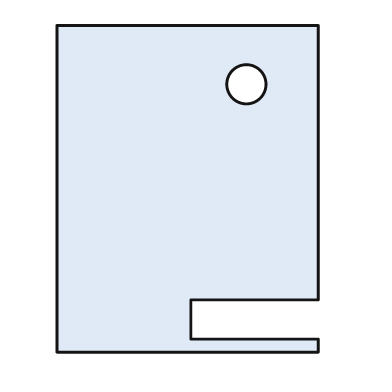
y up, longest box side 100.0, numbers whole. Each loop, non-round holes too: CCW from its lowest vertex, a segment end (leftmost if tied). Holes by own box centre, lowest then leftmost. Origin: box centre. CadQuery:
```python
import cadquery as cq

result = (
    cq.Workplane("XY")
    .moveTo(-40.0, -50.0)
    .lineTo(40.0, -50.0)
    .lineTo(40.0, -46.0)
    .lineTo(1.0, -46.0)
    .lineTo(1.0, -34.0)
    .lineTo(40.0, -34.0)
    .lineTo(40.0, 50.0)
    .lineTo(-40.0, 50.0)
    .close()
    .moveTo(18.0, 32.0)
    .circle(6.0)
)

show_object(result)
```